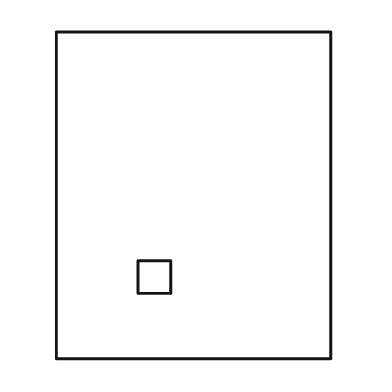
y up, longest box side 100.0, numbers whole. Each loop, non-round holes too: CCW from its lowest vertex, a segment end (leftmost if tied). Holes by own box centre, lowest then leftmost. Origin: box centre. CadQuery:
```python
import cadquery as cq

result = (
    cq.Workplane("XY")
    .moveTo(-42.0, -50.0)
    .lineTo(42.0, -50.0)
    .lineTo(42.0, 50.0)
    .lineTo(-42.0, 50.0)
    .close()
    .moveTo(-17.0, -30.0)
    .lineTo(-7.0, -30.0)
    .lineTo(-7.0, -20.0)
    .lineTo(-17.0, -20.0)
    .close()
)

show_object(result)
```